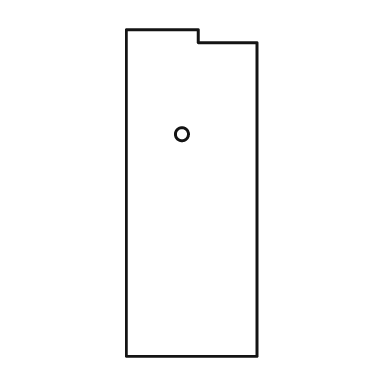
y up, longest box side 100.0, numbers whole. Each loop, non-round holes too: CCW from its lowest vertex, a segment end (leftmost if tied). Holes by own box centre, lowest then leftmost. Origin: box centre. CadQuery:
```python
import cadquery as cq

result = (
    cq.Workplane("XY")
    .moveTo(-20.0, -50.0)
    .lineTo(20.0, -50.0)
    .lineTo(20.0, 46.0)
    .lineTo(2.0, 46.0)
    .lineTo(2.0, 50.0)
    .lineTo(-20.0, 50.0)
    .close()
    .moveTo(-3.0, 18.0)
    .circle(2.0)
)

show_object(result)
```